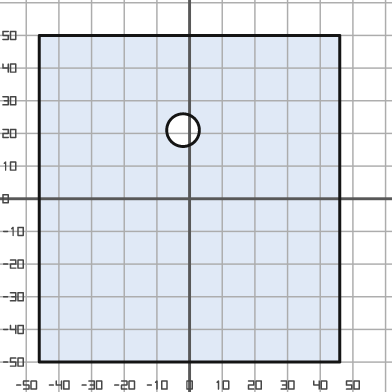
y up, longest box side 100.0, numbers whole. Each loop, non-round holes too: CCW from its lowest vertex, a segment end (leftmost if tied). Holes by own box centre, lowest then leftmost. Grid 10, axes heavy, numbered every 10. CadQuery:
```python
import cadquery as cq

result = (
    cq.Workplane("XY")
    .moveTo(-46.0, -50.0)
    .lineTo(46.0, -50.0)
    .lineTo(46.0, 50.0)
    .lineTo(-46.0, 50.0)
    .close()
    .moveTo(-2.0, 21.0)
    .circle(5.0)
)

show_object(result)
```